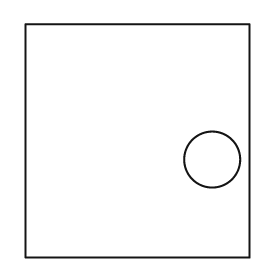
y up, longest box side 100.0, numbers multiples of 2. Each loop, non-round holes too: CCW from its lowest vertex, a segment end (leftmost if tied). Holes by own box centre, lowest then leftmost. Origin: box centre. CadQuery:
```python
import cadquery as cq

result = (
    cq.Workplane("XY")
    .moveTo(-48.0, -50.0)
    .lineTo(48.0, -50.0)
    .lineTo(48.0, 50.0)
    .lineTo(-48.0, 50.0)
    .close()
    .moveTo(32.0, -8.0)
    .circle(12.0)
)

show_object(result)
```